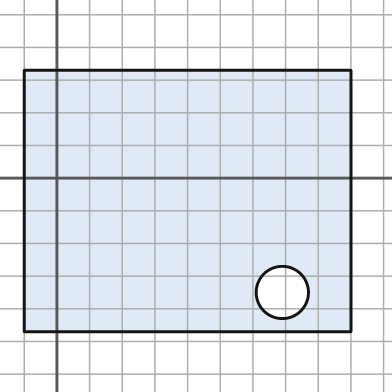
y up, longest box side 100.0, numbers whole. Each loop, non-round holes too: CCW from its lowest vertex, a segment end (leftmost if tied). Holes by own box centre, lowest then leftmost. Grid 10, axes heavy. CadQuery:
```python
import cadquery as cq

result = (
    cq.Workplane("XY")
    .moveTo(-10.0, -47.0)
    .lineTo(90.0, -47.0)
    .lineTo(90.0, 33.0)
    .lineTo(-10.0, 33.0)
    .close()
    .moveTo(69.0, -35.0)
    .circle(8.0)
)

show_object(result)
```